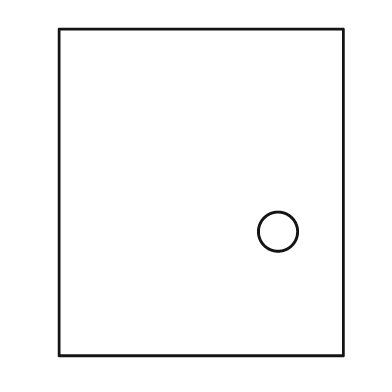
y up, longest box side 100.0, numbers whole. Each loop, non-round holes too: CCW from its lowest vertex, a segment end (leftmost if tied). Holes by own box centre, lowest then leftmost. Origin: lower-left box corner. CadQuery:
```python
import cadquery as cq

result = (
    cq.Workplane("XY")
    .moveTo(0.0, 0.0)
    .lineTo(87.0, 0.0)
    .lineTo(87.0, 100.0)
    .lineTo(0.0, 100.0)
    .close()
    .moveTo(67.0, 38.0)
    .circle(6.0)
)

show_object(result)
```